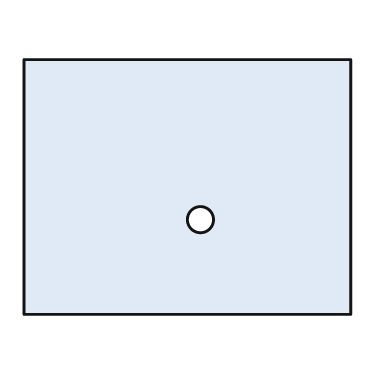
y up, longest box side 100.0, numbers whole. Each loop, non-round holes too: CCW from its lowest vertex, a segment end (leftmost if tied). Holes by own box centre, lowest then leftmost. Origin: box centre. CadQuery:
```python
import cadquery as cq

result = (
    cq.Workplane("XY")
    .moveTo(-50.0, -39.0)
    .lineTo(50.0, -39.0)
    .lineTo(50.0, 39.0)
    .lineTo(-50.0, 39.0)
    .close()
    .moveTo(4.0, -10.0)
    .circle(4.0)
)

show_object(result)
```